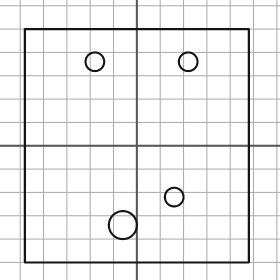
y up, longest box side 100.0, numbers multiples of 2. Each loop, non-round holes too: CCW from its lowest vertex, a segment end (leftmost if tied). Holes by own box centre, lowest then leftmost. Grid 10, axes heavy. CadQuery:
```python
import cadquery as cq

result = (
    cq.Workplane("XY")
    .moveTo(-48.0, -50.0)
    .lineTo(48.0, -50.0)
    .lineTo(48.0, 50.0)
    .lineTo(-48.0, 50.0)
    .close()
    .moveTo(-6.0, -34.0)
    .circle(6.0)
    .moveTo(16.0, -22.0)
    .circle(4.0)
    .moveTo(-18.0, 36.0)
    .circle(4.0)
    .moveTo(22.0, 36.0)
    .circle(4.0)
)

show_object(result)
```